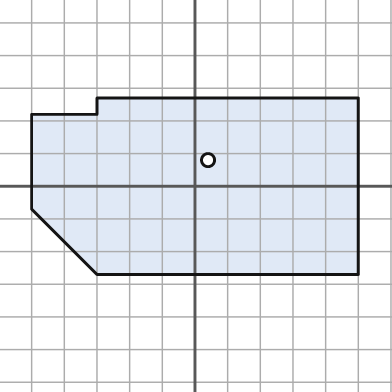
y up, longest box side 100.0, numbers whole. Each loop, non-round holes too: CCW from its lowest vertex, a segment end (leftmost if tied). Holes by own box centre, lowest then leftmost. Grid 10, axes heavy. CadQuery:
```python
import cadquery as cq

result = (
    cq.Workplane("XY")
    .moveTo(-30.0, -27.0)
    .lineTo(50.0, -27.0)
    .lineTo(50.0, 27.0)
    .lineTo(-30.0, 27.0)
    .lineTo(-30.0, 22.0)
    .lineTo(-50.0, 22.0)
    .lineTo(-50.0, -7.0)
    .close()
    .moveTo(4.0, 8.0)
    .circle(2.0)
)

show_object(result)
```